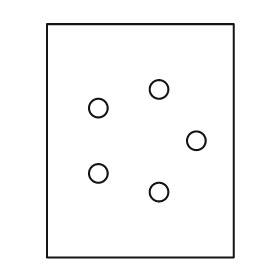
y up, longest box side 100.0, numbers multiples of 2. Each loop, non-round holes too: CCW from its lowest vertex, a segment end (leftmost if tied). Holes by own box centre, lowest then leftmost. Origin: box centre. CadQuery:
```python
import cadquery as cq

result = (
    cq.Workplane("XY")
    .moveTo(-40.0, -50.0)
    .lineTo(40.0, -50.0)
    .lineTo(40.0, 50.0)
    .lineTo(-40.0, 50.0)
    .close()
    .moveTo(8.0, -22.0)
    .circle(4.0)
    .moveTo(-18.0, -14.0)
    .circle(4.0)
    .moveTo(24.0, 0.0)
    .circle(4.0)
    .moveTo(-18.0, 14.0)
    .circle(4.0)
    .moveTo(8.0, 22.0)
    .circle(4.0)
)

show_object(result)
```